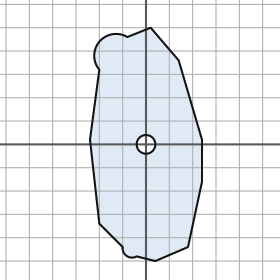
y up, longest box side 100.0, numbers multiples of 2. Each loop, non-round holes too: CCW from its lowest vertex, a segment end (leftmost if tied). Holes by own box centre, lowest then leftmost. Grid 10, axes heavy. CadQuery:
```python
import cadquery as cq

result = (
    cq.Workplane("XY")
    .moveTo(4.0, -50.0)
    .lineTo(18.0, -44.0)
    .lineTo(24.0, -16.0)
    .lineTo(24.0, 2.0)
    .lineTo(14.0, 36.0)
    .lineTo(2.0, 50.0)
    .lineTo(-8.0, 46.0)
    .threePointArc((-20.0, 44.0), (-20.0, 32.0))
    .lineTo(-24.0, 2.0)
    .lineTo(-20.0, -34.0)
    .lineTo(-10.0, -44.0)
    .threePointArc((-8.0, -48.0), (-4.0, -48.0))
    .close()
    .moveTo(0.0, 0.0)
    .circle(4.0)
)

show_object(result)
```